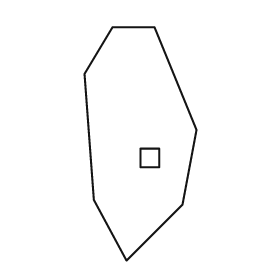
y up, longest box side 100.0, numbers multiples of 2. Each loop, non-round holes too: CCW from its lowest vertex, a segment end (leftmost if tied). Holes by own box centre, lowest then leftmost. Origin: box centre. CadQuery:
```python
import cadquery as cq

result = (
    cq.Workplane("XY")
    .moveTo(-6.0, -50.0)
    .lineTo(18.0, -26.0)
    .lineTo(24.0, 6.0)
    .lineTo(6.0, 50.0)
    .lineTo(-12.0, 50.0)
    .lineTo(-24.0, 30.0)
    .lineTo(-20.0, -24.0)
    .close()
    .moveTo(0.0, -10.0)
    .lineTo(8.0, -10.0)
    .lineTo(8.0, -2.0)
    .lineTo(0.0, -2.0)
    .close()
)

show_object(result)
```